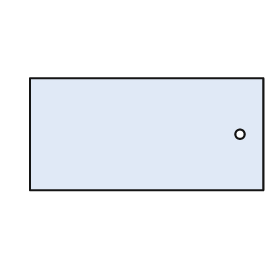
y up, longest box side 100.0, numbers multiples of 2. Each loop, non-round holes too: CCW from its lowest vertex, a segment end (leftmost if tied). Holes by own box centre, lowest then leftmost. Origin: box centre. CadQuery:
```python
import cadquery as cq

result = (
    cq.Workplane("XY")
    .moveTo(-50.0, -24.0)
    .lineTo(50.0, -24.0)
    .lineTo(50.0, 24.0)
    .lineTo(-50.0, 24.0)
    .close()
    .moveTo(40.0, 0.0)
    .circle(2.0)
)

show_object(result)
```